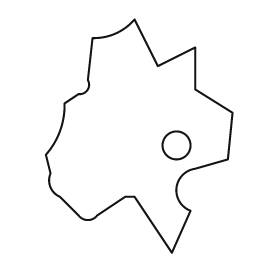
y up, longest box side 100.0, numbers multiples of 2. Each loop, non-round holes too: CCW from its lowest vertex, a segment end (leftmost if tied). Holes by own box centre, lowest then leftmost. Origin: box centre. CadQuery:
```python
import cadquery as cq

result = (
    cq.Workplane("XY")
    .moveTo(14.0, -50.0)
    .lineTo(22.0, -32.0)
    .threePointArc((16.0, -22.0), (24.0, -14.0))
    .lineTo(38.0, -10.0)
    .lineTo(40.0, 10.0)
    .lineTo(24.0, 20.0)
    .lineTo(24.0, 38.0)
    .lineTo(8.0, 30.0)
    .lineTo(-2.0, 50.0)
    .threePointArc((-10.0, 44.0), (-20.0, 42.0))
    .lineTo(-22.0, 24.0)
    .threePointArc((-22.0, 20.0), (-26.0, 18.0))
    .lineTo(-32.0, 14.0)
    .threePointArc((-34.0, 2.0), (-40.0, -8.0))
    .lineTo(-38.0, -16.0)
    .threePointArc((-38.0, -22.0), (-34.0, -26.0))
    .lineTo(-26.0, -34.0)
    .threePointArc((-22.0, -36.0), (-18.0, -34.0))
    .lineTo(-6.0, -26.0)
    .lineTo(-2.0, -26.0)
    .close()
    .moveTo(16.0, -4.0)
    .circle(6.0)
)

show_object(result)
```